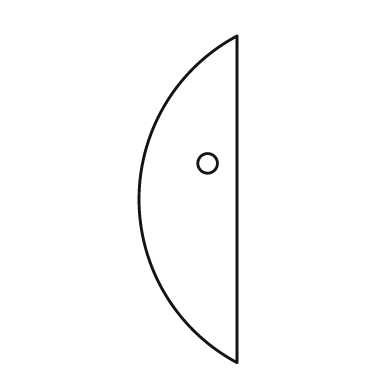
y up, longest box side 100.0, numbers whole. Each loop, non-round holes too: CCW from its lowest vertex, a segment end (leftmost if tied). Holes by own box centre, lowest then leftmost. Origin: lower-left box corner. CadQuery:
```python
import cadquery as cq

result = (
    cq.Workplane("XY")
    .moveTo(30.0, 0.0)
    .lineTo(30.0, 100.0)
    .threePointArc((0.0, 50.0), (30.0, 0.0))
    .close()
    .moveTo(21.0, 61.0)
    .circle(3.0)
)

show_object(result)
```